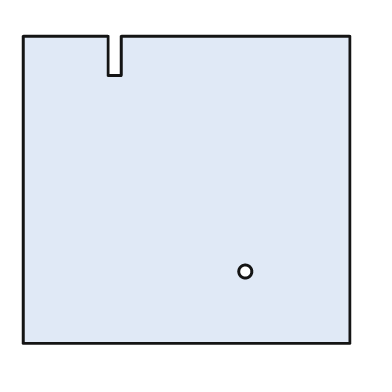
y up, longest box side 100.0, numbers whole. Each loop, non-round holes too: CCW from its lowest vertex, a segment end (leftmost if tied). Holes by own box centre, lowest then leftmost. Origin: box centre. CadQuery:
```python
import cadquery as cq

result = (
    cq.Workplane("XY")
    .moveTo(-50.0, -47.0)
    .lineTo(50.0, -47.0)
    .lineTo(50.0, 47.0)
    .lineTo(-20.0, 47.0)
    .lineTo(-20.0, 35.0)
    .lineTo(-24.0, 35.0)
    .lineTo(-24.0, 47.0)
    .lineTo(-50.0, 47.0)
    .close()
    .moveTo(18.0, -25.0)
    .circle(2.0)
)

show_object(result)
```